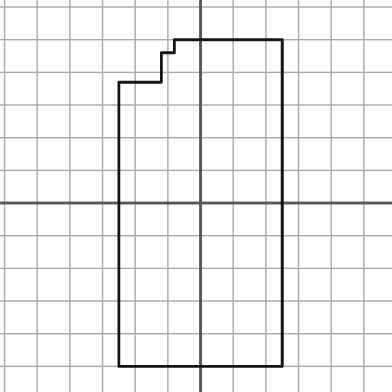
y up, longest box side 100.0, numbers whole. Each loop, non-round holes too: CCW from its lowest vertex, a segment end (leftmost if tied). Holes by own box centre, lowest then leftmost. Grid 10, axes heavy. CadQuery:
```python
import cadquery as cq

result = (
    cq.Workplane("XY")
    .moveTo(-25.0, -50.0)
    .lineTo(25.0, -50.0)
    .lineTo(25.0, 50.0)
    .lineTo(-8.0, 50.0)
    .lineTo(-8.0, 46.0)
    .lineTo(-12.0, 46.0)
    .lineTo(-12.0, 37.0)
    .lineTo(-25.0, 37.0)
    .close()
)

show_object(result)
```